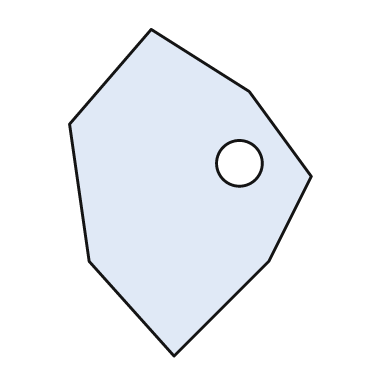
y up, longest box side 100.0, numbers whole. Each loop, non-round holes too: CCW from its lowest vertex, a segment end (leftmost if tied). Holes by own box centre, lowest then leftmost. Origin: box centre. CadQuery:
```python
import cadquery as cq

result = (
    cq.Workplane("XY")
    .moveTo(-5.0, -50.0)
    .lineTo(24.0, -21.0)
    .lineTo(37.0, 5.0)
    .lineTo(18.0, 31.0)
    .lineTo(-12.0, 50.0)
    .lineTo(-37.0, 21.0)
    .lineTo(-31.0, -21.0)
    .close()
    .moveTo(15.0, 9.0)
    .circle(7.0)
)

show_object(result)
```